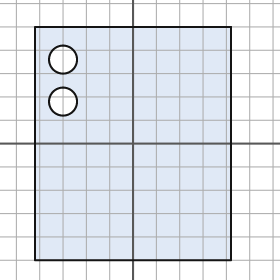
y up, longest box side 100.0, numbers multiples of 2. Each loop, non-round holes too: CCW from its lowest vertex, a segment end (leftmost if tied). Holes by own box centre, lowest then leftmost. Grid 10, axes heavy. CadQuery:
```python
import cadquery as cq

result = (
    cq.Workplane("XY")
    .moveTo(-42.0, -50.0)
    .lineTo(42.0, -50.0)
    .lineTo(42.0, 50.0)
    .lineTo(-42.0, 50.0)
    .close()
    .moveTo(-30.0, 18.0)
    .circle(6.0)
    .moveTo(-30.0, 36.0)
    .circle(6.0)
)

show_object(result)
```